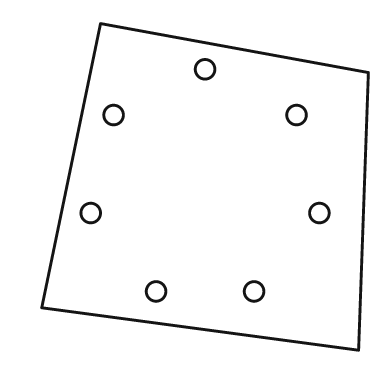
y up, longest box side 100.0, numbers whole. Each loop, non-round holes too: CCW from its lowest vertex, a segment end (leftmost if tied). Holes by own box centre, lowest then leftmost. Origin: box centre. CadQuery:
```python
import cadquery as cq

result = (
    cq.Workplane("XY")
    .moveTo(47.0, -50.0)
    .lineTo(50.0, 35.0)
    .lineTo(-32.0, 50.0)
    .lineTo(-50.0, -37.0)
    .close()
    .moveTo(-15.0, -32.0)
    .circle(3.0)
    .moveTo(15.0, -32.0)
    .circle(3.0)
    .moveTo(-35.0, -8.0)
    .circle(3.0)
    .moveTo(35.0, -8.0)
    .circle(3.0)
    .moveTo(-28.0, 22.0)
    .circle(3.0)
    .moveTo(28.0, 22.0)
    .circle(3.0)
    .moveTo(0.0, 36.0)
    .circle(3.0)
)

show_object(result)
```